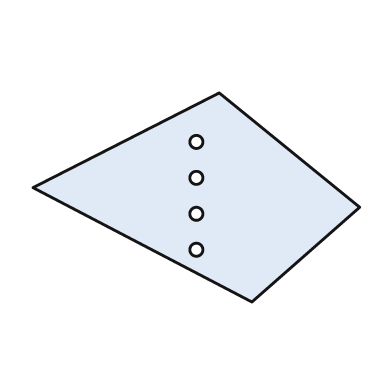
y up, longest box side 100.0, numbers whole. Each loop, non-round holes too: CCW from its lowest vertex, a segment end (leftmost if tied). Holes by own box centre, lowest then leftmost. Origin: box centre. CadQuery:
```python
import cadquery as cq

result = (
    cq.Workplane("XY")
    .moveTo(17.0, -32.0)
    .lineTo(50.0, -3.0)
    .lineTo(7.0, 32.0)
    .lineTo(-50.0, 3.0)
    .close()
    .moveTo(0.0, -16.0)
    .circle(2.0)
    .moveTo(0.0, -5.0)
    .circle(2.0)
    .moveTo(0.0, 6.0)
    .circle(2.0)
    .moveTo(0.0, 17.0)
    .circle(2.0)
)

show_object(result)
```